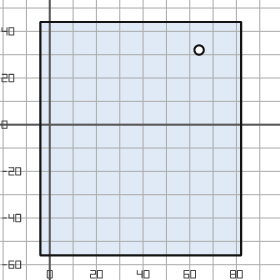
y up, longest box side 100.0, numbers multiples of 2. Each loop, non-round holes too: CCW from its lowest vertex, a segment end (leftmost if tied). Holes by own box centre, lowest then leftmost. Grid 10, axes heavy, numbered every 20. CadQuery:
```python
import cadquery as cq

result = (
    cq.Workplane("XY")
    .moveTo(-4.0, -56.0)
    .lineTo(82.0, -56.0)
    .lineTo(82.0, 44.0)
    .lineTo(-4.0, 44.0)
    .close()
    .moveTo(64.0, 32.0)
    .circle(2.0)
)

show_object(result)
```